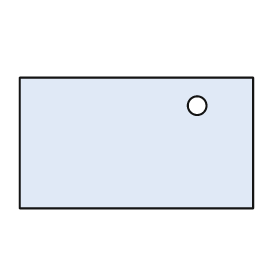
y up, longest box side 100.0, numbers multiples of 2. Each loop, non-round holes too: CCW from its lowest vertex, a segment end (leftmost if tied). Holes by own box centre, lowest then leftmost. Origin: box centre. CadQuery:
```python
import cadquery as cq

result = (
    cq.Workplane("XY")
    .moveTo(-50.0, -28.0)
    .lineTo(50.0, -28.0)
    .lineTo(50.0, 28.0)
    .lineTo(-50.0, 28.0)
    .close()
    .moveTo(26.0, 16.0)
    .circle(4.0)
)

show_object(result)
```